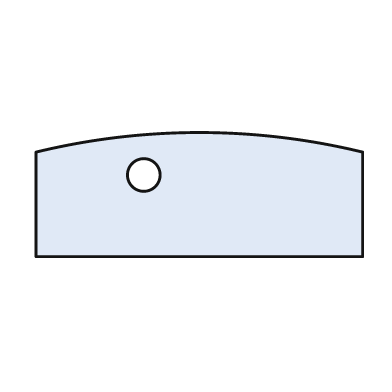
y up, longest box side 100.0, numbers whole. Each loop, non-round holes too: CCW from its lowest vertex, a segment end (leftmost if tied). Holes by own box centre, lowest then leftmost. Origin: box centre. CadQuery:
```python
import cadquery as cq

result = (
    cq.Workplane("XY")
    .moveTo(-50.0, -19.0)
    .lineTo(50.0, -19.0)
    .lineTo(50.0, 13.0)
    .threePointArc((0.0, 19.0), (-50.0, 13.0))
    .close()
    .moveTo(-17.0, 6.0)
    .circle(5.0)
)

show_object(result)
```